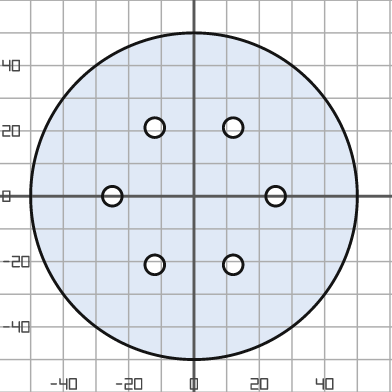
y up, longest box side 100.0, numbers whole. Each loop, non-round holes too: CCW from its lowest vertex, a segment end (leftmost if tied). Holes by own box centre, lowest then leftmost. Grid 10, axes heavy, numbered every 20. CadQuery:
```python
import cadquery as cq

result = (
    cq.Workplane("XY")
    .moveTo(0.0, 0.0)
    .circle(50.0)
    .moveTo(-12.0, -21.0)
    .circle(3.0)
    .moveTo(12.0, -21.0)
    .circle(3.0)
    .moveTo(-25.0, 0.0)
    .circle(3.0)
    .moveTo(25.0, 0.0)
    .circle(3.0)
    .moveTo(-12.0, 21.0)
    .circle(3.0)
    .moveTo(12.0, 21.0)
    .circle(3.0)
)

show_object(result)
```